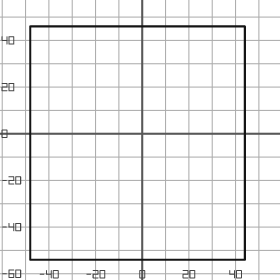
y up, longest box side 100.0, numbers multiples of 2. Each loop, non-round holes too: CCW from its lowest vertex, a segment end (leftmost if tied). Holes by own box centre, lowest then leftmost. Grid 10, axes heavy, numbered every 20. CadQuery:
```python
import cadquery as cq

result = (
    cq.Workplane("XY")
    .moveTo(-48.0, -54.0)
    .lineTo(44.0, -54.0)
    .lineTo(44.0, 46.0)
    .lineTo(-48.0, 46.0)
    .close()
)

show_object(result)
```